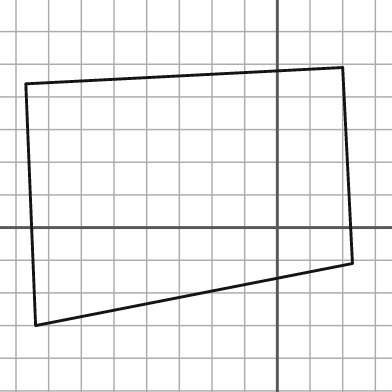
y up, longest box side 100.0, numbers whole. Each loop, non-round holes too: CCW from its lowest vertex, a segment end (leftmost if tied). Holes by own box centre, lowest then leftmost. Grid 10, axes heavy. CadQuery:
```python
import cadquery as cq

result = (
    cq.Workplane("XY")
    .moveTo(-74.0, -30.0)
    .lineTo(23.0, -11.0)
    .lineTo(20.0, 49.0)
    .lineTo(-77.0, 44.0)
    .close()
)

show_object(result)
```